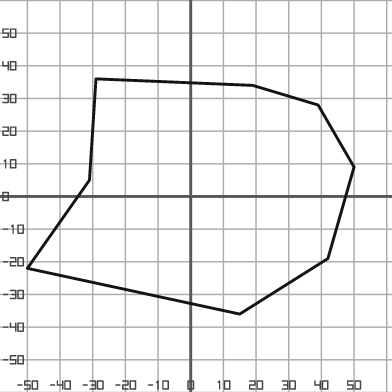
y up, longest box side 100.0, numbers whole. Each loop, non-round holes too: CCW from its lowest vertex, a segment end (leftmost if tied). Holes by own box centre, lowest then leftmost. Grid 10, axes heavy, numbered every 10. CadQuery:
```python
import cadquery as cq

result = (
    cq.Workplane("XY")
    .moveTo(15.0, -36.0)
    .lineTo(42.0, -19.0)
    .lineTo(50.0, 9.0)
    .lineTo(39.0, 28.0)
    .lineTo(19.0, 34.0)
    .lineTo(-29.0, 36.0)
    .lineTo(-31.0, 5.0)
    .lineTo(-50.0, -22.0)
    .close()
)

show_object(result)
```